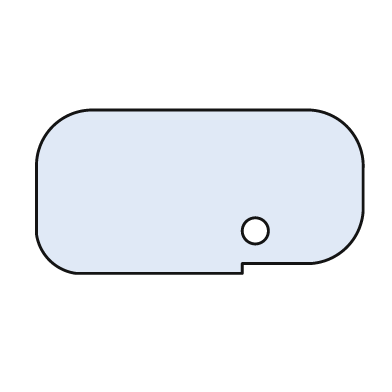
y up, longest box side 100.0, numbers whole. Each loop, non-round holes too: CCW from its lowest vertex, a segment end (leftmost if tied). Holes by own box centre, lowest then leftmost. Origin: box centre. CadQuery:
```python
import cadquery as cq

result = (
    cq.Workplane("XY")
    .moveTo(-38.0, -25.0)
    .lineTo(13.0, -25.0)
    .lineTo(13.0, -22.0)
    .lineTo(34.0, -22.0)
    .threePointArc((45.0, -17.0), (50.0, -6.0))
    .lineTo(50.0, 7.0)
    .threePointArc((45.0, 20.0), (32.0, 25.0))
    .lineTo(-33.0, 25.0)
    .threePointArc((-45.0, 20.0), (-50.0, 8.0))
    .lineTo(-50.0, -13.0)
    .threePointArc((-46.0, -21.0), (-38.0, -25.0))
    .close()
    .moveTo(17.0, -12.0)
    .circle(4.0)
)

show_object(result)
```